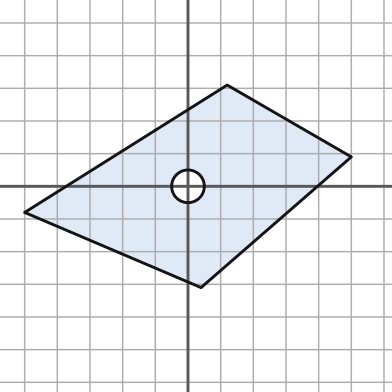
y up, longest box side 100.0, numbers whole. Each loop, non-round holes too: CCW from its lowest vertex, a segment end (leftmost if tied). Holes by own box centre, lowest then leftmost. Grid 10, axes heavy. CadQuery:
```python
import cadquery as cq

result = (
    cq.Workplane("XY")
    .moveTo(4.0, -31.0)
    .lineTo(50.0, 9.0)
    .lineTo(12.0, 31.0)
    .lineTo(-50.0, -8.0)
    .close()
    .moveTo(0.0, 0.0)
    .circle(5.0)
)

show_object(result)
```